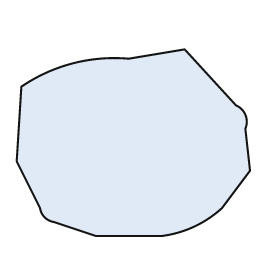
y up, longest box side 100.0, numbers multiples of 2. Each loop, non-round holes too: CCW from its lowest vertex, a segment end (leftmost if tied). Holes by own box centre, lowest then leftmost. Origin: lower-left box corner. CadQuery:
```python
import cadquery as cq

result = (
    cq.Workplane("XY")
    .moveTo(34.0, 0.0)
    .lineTo(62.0, 0.0)
    .threePointArc((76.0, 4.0), (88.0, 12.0))
    .lineTo(100.0, 28.0)
    .lineTo(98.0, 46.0)
    .threePointArc((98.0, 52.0), (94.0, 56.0))
    .lineTo(72.0, 80.0)
    .lineTo(48.0, 76.0)
    .threePointArc((24.0, 74.0), (2.0, 64.0))
    .lineTo(0.0, 32.0)
    .lineTo(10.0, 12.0)
    .threePointArc((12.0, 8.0), (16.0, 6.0))
    .close()
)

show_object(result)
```